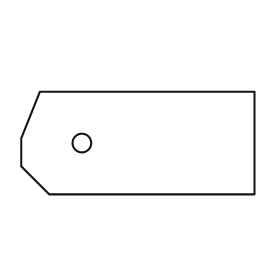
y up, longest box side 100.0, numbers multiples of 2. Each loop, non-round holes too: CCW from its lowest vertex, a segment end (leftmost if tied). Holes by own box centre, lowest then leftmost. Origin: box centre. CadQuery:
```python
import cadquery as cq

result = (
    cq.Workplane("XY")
    .moveTo(-38.0, -22.0)
    .lineTo(50.0, -22.0)
    .lineTo(50.0, 22.0)
    .lineTo(-42.0, 22.0)
    .lineTo(-50.0, 2.0)
    .lineTo(-50.0, -10.0)
    .close()
    .moveTo(-24.0, 0.0)
    .circle(4.0)
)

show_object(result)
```